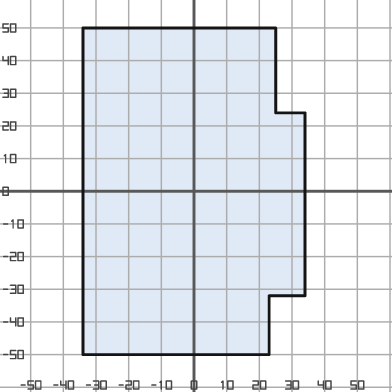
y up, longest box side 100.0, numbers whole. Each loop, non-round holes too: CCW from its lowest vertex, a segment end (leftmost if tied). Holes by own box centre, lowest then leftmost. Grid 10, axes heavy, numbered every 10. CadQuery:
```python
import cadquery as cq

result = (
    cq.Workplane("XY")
    .moveTo(-34.0, -50.0)
    .lineTo(23.0, -50.0)
    .lineTo(23.0, -32.0)
    .lineTo(34.0, -32.0)
    .lineTo(34.0, 24.0)
    .lineTo(25.0, 24.0)
    .lineTo(25.0, 50.0)
    .lineTo(-34.0, 50.0)
    .close()
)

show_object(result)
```